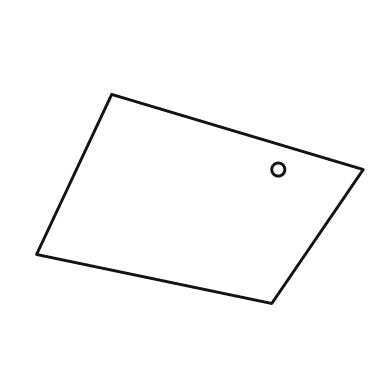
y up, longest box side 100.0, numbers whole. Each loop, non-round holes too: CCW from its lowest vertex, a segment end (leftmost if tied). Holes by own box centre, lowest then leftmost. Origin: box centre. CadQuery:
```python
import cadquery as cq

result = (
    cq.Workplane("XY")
    .moveTo(22.0, -32.0)
    .lineTo(50.0, 9.0)
    .lineTo(-27.0, 32.0)
    .lineTo(-50.0, -17.0)
    .close()
    .moveTo(24.0, 9.0)
    .circle(2.0)
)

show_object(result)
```